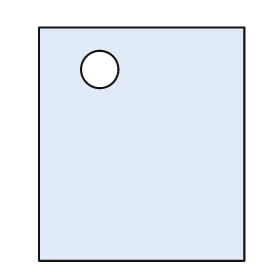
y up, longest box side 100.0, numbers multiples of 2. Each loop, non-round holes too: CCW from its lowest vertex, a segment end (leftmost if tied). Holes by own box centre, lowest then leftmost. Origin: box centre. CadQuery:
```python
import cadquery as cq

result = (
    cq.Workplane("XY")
    .moveTo(-44.0, -50.0)
    .lineTo(44.0, -50.0)
    .lineTo(44.0, 50.0)
    .lineTo(-44.0, 50.0)
    .close()
    .moveTo(-18.0, 32.0)
    .circle(8.0)
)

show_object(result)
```